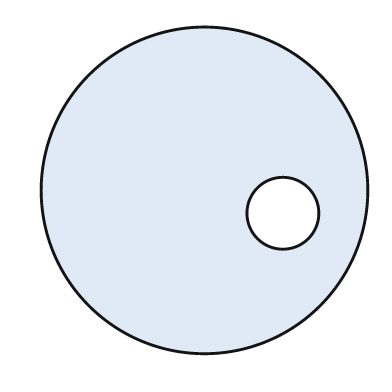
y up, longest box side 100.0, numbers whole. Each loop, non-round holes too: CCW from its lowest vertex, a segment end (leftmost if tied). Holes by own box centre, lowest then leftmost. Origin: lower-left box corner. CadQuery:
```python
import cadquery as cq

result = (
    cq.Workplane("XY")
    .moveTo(50.0, 50.0)
    .circle(50.0)
    .moveTo(74.0, 43.0)
    .circle(11.0)
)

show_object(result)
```